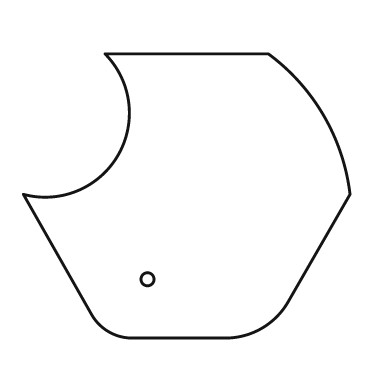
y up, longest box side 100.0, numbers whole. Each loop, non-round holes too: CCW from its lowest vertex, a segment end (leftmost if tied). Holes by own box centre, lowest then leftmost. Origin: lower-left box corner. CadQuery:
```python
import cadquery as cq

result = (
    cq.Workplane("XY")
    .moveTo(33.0, 0.0)
    .lineTo(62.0, 0.0)
    .threePointArc((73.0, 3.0), (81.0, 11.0))
    .lineTo(100.0, 44.0)
    .threePointArc((92.0, 68.0), (75.0, 87.0))
    .lineTo(25.0, 87.0)
    .threePointArc((29.0, 56.0), (0.0, 44.0))
    .lineTo(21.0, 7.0)
    .threePointArc((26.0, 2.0), (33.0, 0.0))
    .close()
    .moveTo(38.0, 18.0)
    .circle(2.0)
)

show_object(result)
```